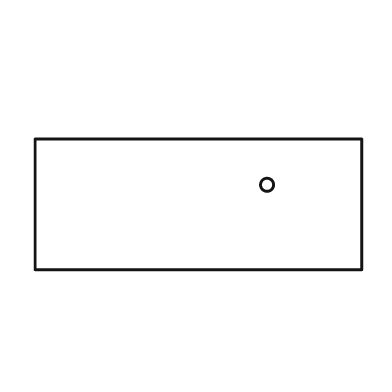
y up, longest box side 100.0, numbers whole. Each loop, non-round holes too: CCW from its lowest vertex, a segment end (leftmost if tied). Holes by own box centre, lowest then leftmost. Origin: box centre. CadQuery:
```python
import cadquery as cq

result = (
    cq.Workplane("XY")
    .moveTo(-50.0, -20.0)
    .lineTo(50.0, -20.0)
    .lineTo(50.0, 20.0)
    .lineTo(-50.0, 20.0)
    .close()
    .moveTo(21.0, 6.0)
    .circle(2.0)
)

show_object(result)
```